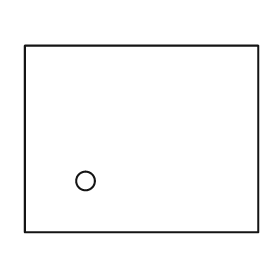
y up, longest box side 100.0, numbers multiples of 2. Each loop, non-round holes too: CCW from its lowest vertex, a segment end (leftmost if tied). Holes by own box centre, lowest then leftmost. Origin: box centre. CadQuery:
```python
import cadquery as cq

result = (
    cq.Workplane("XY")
    .moveTo(-50.0, -40.0)
    .lineTo(50.0, -40.0)
    .lineTo(50.0, 40.0)
    .lineTo(-50.0, 40.0)
    .close()
    .moveTo(-24.0, -18.0)
    .circle(4.0)
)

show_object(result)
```